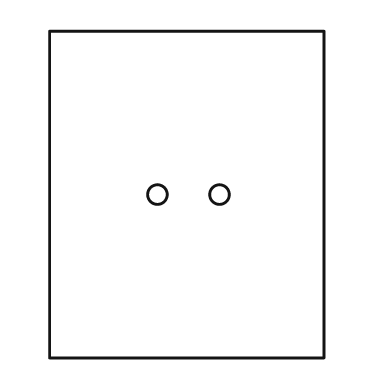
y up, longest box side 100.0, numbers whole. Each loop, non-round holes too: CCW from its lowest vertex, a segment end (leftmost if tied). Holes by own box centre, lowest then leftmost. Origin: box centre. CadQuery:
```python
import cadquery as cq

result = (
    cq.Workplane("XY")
    .moveTo(-42.0, -50.0)
    .lineTo(42.0, -50.0)
    .lineTo(42.0, 50.0)
    .lineTo(-42.0, 50.0)
    .close()
    .moveTo(-9.0, 0.0)
    .circle(3.0)
    .moveTo(10.0, 0.0)
    .circle(3.0)
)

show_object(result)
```